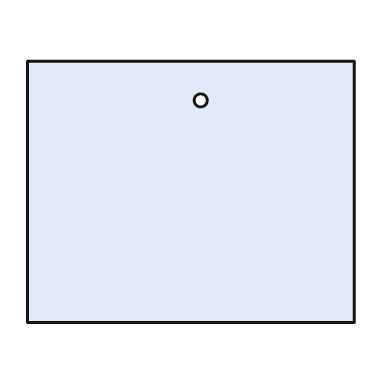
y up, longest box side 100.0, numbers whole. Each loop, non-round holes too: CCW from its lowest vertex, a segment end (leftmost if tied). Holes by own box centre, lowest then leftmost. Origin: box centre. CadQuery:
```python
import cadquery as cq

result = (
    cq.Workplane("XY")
    .moveTo(-50.0, -40.0)
    .lineTo(50.0, -40.0)
    .lineTo(50.0, 40.0)
    .lineTo(-50.0, 40.0)
    .close()
    .moveTo(3.0, 28.0)
    .circle(2.0)
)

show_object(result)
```